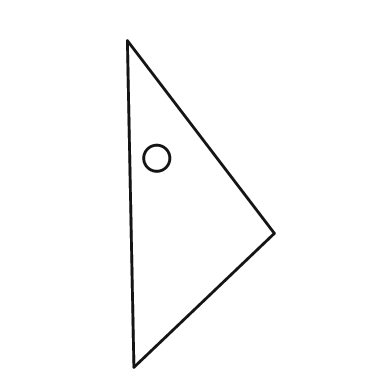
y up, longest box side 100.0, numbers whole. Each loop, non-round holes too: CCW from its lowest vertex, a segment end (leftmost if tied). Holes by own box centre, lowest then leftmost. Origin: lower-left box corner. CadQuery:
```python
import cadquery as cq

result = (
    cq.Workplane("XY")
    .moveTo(2.0, 0.0)
    .lineTo(45.0, 41.0)
    .lineTo(0.0, 100.0)
    .close()
    .moveTo(9.0, 64.0)
    .circle(4.0)
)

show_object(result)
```